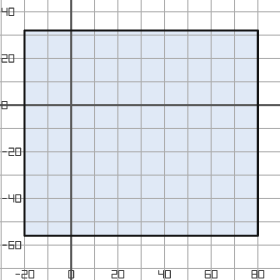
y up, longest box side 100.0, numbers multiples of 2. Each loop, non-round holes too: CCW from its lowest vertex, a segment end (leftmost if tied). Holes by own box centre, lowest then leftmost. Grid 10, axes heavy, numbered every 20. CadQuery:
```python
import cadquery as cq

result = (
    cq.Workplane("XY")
    .moveTo(-20.0, -56.0)
    .lineTo(80.0, -56.0)
    .lineTo(80.0, 32.0)
    .lineTo(-20.0, 32.0)
    .close()
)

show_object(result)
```